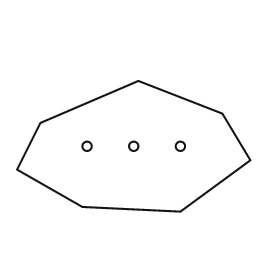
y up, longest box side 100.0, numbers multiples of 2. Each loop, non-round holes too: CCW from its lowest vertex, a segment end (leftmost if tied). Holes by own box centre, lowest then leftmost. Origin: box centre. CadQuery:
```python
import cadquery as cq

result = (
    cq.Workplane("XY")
    .moveTo(20.0, -28.0)
    .lineTo(50.0, -6.0)
    .lineTo(38.0, 14.0)
    .lineTo(2.0, 28.0)
    .lineTo(-40.0, 10.0)
    .lineTo(-50.0, -10.0)
    .lineTo(-22.0, -26.0)
    .close()
    .moveTo(-20.0, 0.0)
    .circle(2.0)
    .moveTo(0.0, 0.0)
    .circle(2.0)
    .moveTo(20.0, 0.0)
    .circle(2.0)
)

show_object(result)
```